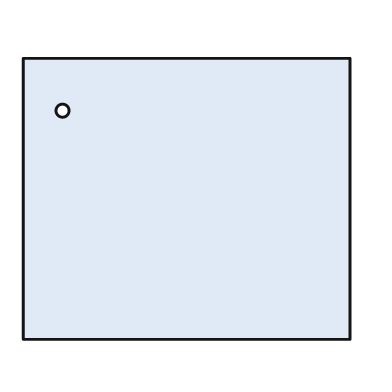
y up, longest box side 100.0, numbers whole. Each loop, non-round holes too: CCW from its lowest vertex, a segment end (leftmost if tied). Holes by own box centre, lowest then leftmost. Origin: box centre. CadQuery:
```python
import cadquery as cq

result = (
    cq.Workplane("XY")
    .moveTo(-50.0, -43.0)
    .lineTo(50.0, -43.0)
    .lineTo(50.0, 43.0)
    .lineTo(-50.0, 43.0)
    .close()
    .moveTo(-38.0, 27.0)
    .circle(2.0)
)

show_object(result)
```